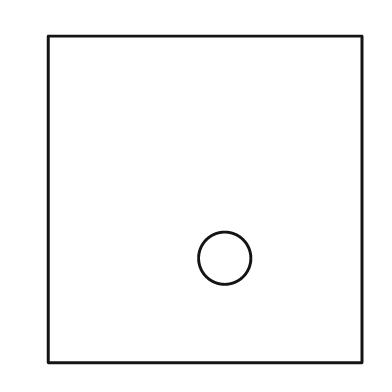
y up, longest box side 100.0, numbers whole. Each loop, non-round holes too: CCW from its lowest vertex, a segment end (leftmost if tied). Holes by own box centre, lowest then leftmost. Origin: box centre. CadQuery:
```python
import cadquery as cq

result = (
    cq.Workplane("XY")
    .moveTo(-48.0, -50.0)
    .lineTo(48.0, -50.0)
    .lineTo(48.0, 50.0)
    .lineTo(-48.0, 50.0)
    .close()
    .moveTo(6.0, -18.0)
    .circle(8.0)
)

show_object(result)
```